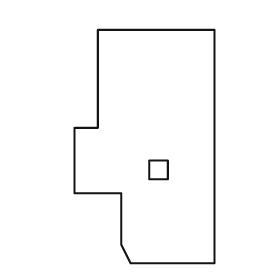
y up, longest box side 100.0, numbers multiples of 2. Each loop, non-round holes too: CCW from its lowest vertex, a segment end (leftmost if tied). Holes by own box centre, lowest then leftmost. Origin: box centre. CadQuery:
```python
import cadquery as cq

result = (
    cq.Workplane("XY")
    .moveTo(-6.0, -50.0)
    .lineTo(30.0, -50.0)
    .lineTo(30.0, 50.0)
    .lineTo(-20.0, 50.0)
    .lineTo(-20.0, 8.0)
    .lineTo(-30.0, 8.0)
    .lineTo(-30.0, -20.0)
    .lineTo(-10.0, -20.0)
    .lineTo(-10.0, -42.0)
    .close()
    .moveTo(2.0, -14.0)
    .lineTo(10.0, -14.0)
    .lineTo(10.0, -6.0)
    .lineTo(2.0, -6.0)
    .close()
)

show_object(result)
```